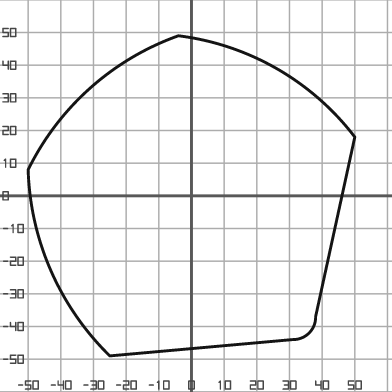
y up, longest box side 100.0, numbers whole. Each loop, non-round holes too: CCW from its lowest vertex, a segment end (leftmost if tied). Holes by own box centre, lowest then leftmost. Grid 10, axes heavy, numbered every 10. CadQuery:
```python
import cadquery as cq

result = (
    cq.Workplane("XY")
    .moveTo(-25.0, -49.0)
    .lineTo(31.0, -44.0)
    .threePointArc((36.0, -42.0), (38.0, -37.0))
    .lineTo(50.0, 18.0)
    .threePointArc((26.0, 39.0), (-4.0, 49.0))
    .threePointArc((-31.0, 33.0), (-50.0, 8.0))
    .threePointArc((-43.0, -23.0), (-25.0, -49.0))
    .close()
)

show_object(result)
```